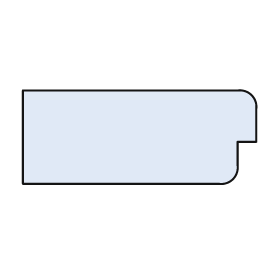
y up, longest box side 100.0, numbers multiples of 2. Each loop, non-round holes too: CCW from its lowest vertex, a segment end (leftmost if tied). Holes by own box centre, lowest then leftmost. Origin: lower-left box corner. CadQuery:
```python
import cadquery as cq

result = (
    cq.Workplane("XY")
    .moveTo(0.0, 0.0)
    .lineTo(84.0, 0.0)
    .threePointArc((90.0, 2.0), (92.0, 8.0))
    .lineTo(92.0, 18.0)
    .lineTo(100.0, 18.0)
    .lineTo(100.0, 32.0)
    .threePointArc((98.0, 38.0), (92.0, 40.0))
    .lineTo(0.0, 40.0)
    .close()
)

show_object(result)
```